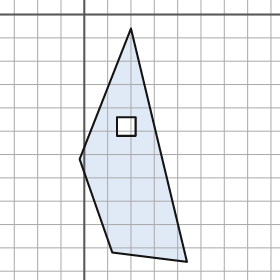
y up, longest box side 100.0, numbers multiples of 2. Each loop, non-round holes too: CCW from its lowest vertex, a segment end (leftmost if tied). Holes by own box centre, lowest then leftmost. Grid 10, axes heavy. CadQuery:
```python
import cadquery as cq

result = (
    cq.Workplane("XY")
    .moveTo(44.0, -106.0)
    .lineTo(20.0, -6.0)
    .lineTo(-2.0, -62.0)
    .lineTo(12.0, -102.0)
    .close()
    .moveTo(14.0, -52.0)
    .lineTo(22.0, -52.0)
    .lineTo(22.0, -44.0)
    .lineTo(14.0, -44.0)
    .close()
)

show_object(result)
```